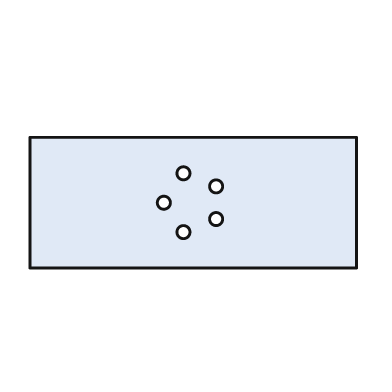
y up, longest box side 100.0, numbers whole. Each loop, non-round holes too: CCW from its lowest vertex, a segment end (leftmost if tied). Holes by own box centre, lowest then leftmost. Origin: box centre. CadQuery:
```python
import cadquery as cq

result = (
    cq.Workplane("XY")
    .moveTo(-50.0, -20.0)
    .lineTo(50.0, -20.0)
    .lineTo(50.0, 20.0)
    .lineTo(-50.0, 20.0)
    .close()
    .moveTo(-3.0, -9.0)
    .circle(2.0)
    .moveTo(7.0, -5.0)
    .circle(2.0)
    .moveTo(-9.0, 0.0)
    .circle(2.0)
    .moveTo(7.0, 5.0)
    .circle(2.0)
    .moveTo(-3.0, 9.0)
    .circle(2.0)
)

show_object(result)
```